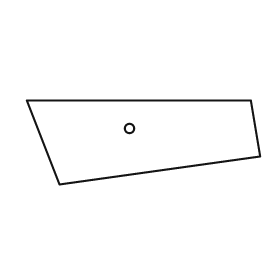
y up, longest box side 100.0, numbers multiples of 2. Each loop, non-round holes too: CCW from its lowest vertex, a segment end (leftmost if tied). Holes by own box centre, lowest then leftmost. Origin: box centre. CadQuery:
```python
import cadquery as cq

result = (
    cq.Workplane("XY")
    .moveTo(-36.0, -18.0)
    .lineTo(50.0, -6.0)
    .lineTo(46.0, 18.0)
    .lineTo(-50.0, 18.0)
    .close()
    .moveTo(-6.0, 6.0)
    .circle(2.0)
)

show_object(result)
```